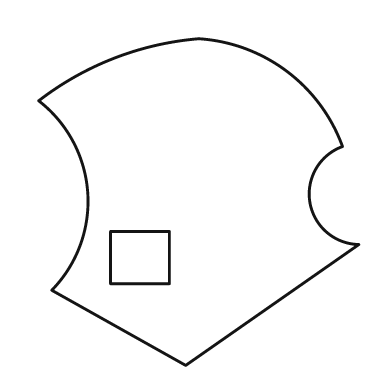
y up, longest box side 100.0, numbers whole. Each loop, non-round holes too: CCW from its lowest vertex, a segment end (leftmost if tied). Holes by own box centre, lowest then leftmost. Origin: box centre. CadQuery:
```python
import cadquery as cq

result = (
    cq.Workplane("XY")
    .moveTo(-4.0, -50.0)
    .lineTo(49.0, -13.0)
    .threePointArc((34.0, 0.0), (44.0, 17.0))
    .threePointArc((27.0, 40.0), (0.0, 50.0))
    .threePointArc((-26.0, 44.0), (-49.0, 31.0))
    .threePointArc((-34.0, 3.0), (-45.0, -27.0))
    .close()
    .moveTo(-27.0, -25.0)
    .lineTo(-9.0, -25.0)
    .lineTo(-9.0, -9.0)
    .lineTo(-27.0, -9.0)
    .close()
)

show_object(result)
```